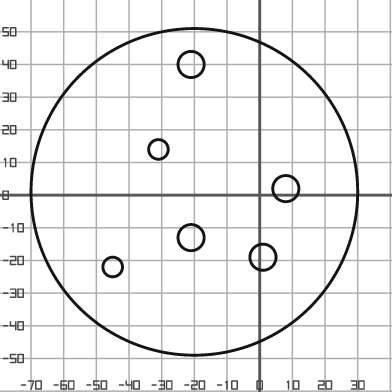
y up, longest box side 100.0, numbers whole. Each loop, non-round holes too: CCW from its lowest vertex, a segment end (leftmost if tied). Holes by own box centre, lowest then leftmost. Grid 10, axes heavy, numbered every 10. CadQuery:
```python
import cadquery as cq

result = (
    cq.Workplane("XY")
    .moveTo(-20.0, 1.0)
    .circle(50.0)
    .moveTo(-45.0, -22.0)
    .circle(3.0)
    .moveTo(1.0, -19.0)
    .circle(4.0)
    .moveTo(-21.0, -13.0)
    .circle(4.0)
    .moveTo(8.0, 2.0)
    .circle(4.0)
    .moveTo(-31.0, 14.0)
    .circle(3.0)
    .moveTo(-21.0, 40.0)
    .circle(4.0)
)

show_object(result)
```